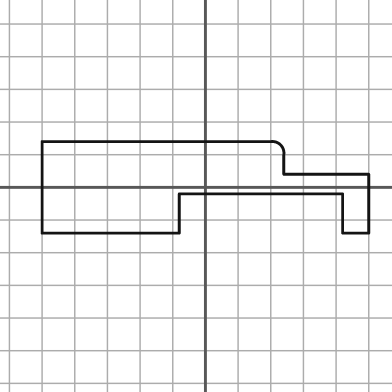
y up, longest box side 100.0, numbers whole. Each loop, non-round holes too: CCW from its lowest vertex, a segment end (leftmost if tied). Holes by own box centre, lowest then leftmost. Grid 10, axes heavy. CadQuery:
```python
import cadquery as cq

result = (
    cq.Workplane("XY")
    .moveTo(-50.0, -14.0)
    .lineTo(-8.0, -14.0)
    .lineTo(-8.0, -2.0)
    .lineTo(42.0, -2.0)
    .lineTo(42.0, -14.0)
    .lineTo(50.0, -14.0)
    .lineTo(50.0, 4.0)
    .lineTo(24.0, 4.0)
    .lineTo(24.0, 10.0)
    .threePointArc((23.0, 13.0), (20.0, 14.0))
    .lineTo(-50.0, 14.0)
    .close()
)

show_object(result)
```